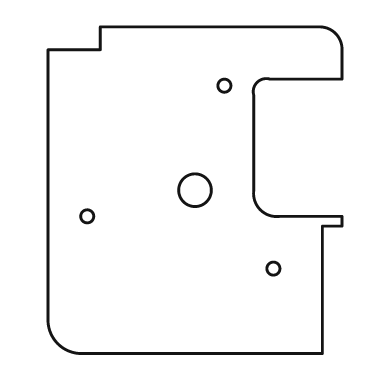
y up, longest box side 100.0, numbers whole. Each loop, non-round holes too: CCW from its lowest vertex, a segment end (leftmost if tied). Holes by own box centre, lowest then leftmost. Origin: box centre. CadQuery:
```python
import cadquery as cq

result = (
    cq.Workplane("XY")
    .moveTo(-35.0, -50.0)
    .lineTo(39.0, -50.0)
    .lineTo(39.0, -11.0)
    .lineTo(45.0, -11.0)
    .lineTo(45.0, -8.0)
    .lineTo(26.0, -8.0)
    .threePointArc((20.0, -6.0), (18.0, 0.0))
    .lineTo(18.0, 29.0)
    .threePointArc((19.0, 33.0), (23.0, 34.0))
    .lineTo(45.0, 34.0)
    .lineTo(45.0, 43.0)
    .threePointArc((43.0, 48.0), (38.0, 50.0))
    .lineTo(-29.0, 50.0)
    .lineTo(-29.0, 43.0)
    .lineTo(-45.0, 43.0)
    .lineTo(-45.0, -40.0)
    .threePointArc((-42.0, -47.0), (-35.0, -50.0))
    .close()
    .moveTo(24.0, -24.0)
    .circle(2.0)
    .moveTo(-33.0, -8.0)
    .circle(2.0)
    .moveTo(0.0, 0.0)
    .circle(5.0)
    .moveTo(9.0, 32.0)
    .circle(2.0)
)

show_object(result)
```